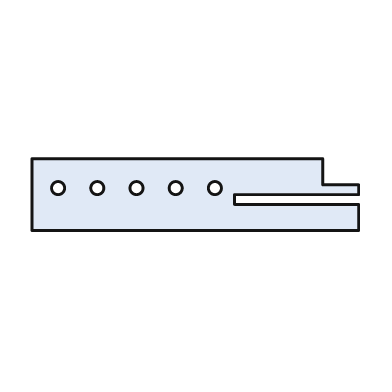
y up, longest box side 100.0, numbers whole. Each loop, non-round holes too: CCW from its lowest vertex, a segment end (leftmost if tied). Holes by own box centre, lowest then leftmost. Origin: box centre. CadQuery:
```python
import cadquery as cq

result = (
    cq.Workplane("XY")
    .moveTo(-50.0, -11.0)
    .lineTo(50.0, -11.0)
    .lineTo(50.0, -3.0)
    .lineTo(12.0, -3.0)
    .lineTo(12.0, 0.0)
    .lineTo(50.0, 0.0)
    .lineTo(50.0, 3.0)
    .lineTo(39.0, 3.0)
    .lineTo(39.0, 11.0)
    .lineTo(-50.0, 11.0)
    .close()
    .moveTo(-42.0, 2.0)
    .circle(2.0)
    .moveTo(-30.0, 2.0)
    .circle(2.0)
    .moveTo(-18.0, 2.0)
    .circle(2.0)
    .moveTo(-6.0, 2.0)
    .circle(2.0)
    .moveTo(6.0, 2.0)
    .circle(2.0)
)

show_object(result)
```